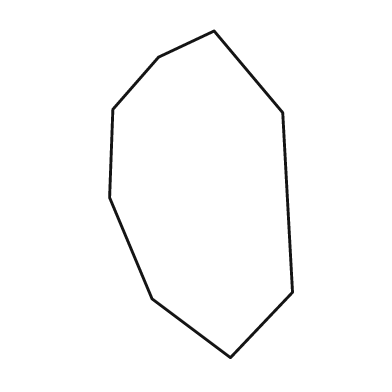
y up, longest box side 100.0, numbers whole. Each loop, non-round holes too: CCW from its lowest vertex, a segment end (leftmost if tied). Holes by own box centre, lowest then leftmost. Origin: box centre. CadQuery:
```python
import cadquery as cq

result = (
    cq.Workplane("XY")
    .moveTo(9.0, -50.0)
    .lineTo(28.0, -30.0)
    .lineTo(25.0, 25.0)
    .lineTo(4.0, 50.0)
    .lineTo(-13.0, 42.0)
    .lineTo(-27.0, 26.0)
    .lineTo(-28.0, -1.0)
    .lineTo(-15.0, -32.0)
    .close()
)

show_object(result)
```